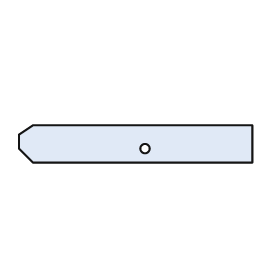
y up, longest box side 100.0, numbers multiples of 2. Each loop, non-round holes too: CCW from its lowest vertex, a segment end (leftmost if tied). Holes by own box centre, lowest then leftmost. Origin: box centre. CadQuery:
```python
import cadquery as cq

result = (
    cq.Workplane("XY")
    .moveTo(-44.0, -8.0)
    .lineTo(50.0, -8.0)
    .lineTo(50.0, 8.0)
    .lineTo(-44.0, 8.0)
    .lineTo(-50.0, 4.0)
    .lineTo(-50.0, -2.0)
    .close()
    .moveTo(4.0, -2.0)
    .circle(2.0)
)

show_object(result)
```